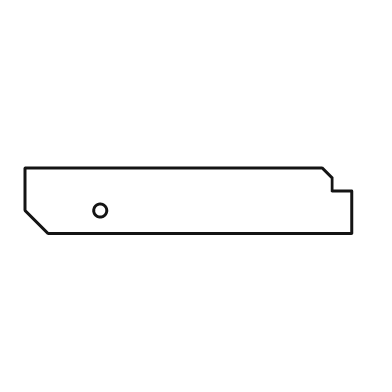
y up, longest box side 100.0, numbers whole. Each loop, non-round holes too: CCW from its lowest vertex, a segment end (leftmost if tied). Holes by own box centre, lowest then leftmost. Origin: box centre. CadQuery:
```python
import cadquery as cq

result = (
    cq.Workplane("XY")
    .moveTo(-43.0, -10.0)
    .lineTo(50.0, -10.0)
    .lineTo(50.0, 3.0)
    .lineTo(44.0, 3.0)
    .lineTo(44.0, 7.0)
    .lineTo(41.0, 10.0)
    .lineTo(-50.0, 10.0)
    .lineTo(-50.0, -3.0)
    .close()
    .moveTo(-27.0, -3.0)
    .circle(2.0)
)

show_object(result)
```